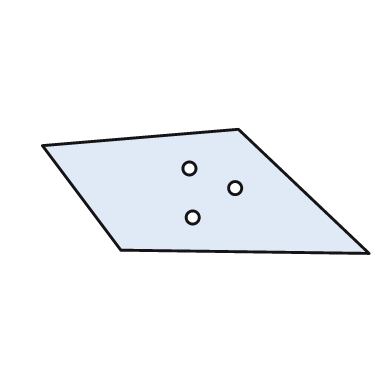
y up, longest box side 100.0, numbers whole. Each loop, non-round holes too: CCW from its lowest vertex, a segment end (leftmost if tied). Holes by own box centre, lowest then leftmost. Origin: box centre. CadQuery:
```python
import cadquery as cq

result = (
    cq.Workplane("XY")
    .moveTo(50.0, -19.0)
    .lineTo(10.0, 19.0)
    .lineTo(-50.0, 14.0)
    .lineTo(-26.0, -18.0)
    .close()
    .moveTo(-4.0, -8.0)
    .circle(2.0)
    .moveTo(9.0, 1.0)
    .circle(2.0)
    .moveTo(-5.0, 7.0)
    .circle(2.0)
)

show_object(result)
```